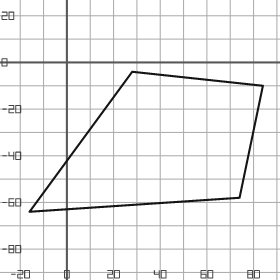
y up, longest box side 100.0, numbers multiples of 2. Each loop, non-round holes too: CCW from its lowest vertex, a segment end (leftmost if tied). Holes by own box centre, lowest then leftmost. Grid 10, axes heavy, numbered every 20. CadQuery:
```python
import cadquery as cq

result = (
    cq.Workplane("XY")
    .moveTo(-16.0, -64.0)
    .lineTo(74.0, -58.0)
    .lineTo(84.0, -10.0)
    .lineTo(28.0, -4.0)
    .close()
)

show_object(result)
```